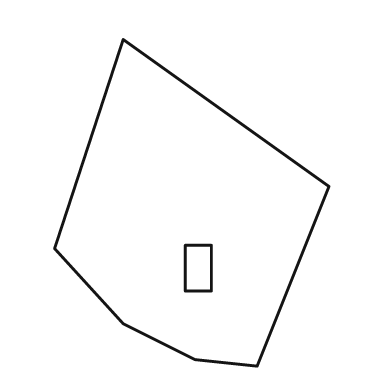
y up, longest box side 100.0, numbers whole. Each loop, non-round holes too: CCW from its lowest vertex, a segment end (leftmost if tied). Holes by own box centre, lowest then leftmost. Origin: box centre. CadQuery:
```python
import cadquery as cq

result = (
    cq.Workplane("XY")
    .moveTo(20.0, -50.0)
    .lineTo(42.0, 5.0)
    .lineTo(-21.0, 50.0)
    .lineTo(-42.0, -14.0)
    .lineTo(-21.0, -37.0)
    .lineTo(1.0, -48.0)
    .close()
    .moveTo(-2.0, -27.0)
    .lineTo(6.0, -27.0)
    .lineTo(6.0, -13.0)
    .lineTo(-2.0, -13.0)
    .close()
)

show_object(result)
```